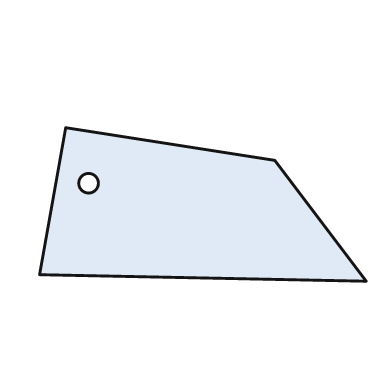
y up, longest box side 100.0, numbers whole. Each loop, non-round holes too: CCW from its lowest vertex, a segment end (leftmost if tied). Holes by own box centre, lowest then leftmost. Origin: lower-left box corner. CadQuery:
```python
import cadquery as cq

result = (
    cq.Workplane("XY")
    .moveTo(100.0, 0.0)
    .lineTo(72.0, 37.0)
    .lineTo(8.0, 47.0)
    .lineTo(0.0, 2.0)
    .close()
    .moveTo(15.0, 30.0)
    .circle(3.0)
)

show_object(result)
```